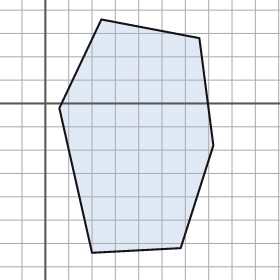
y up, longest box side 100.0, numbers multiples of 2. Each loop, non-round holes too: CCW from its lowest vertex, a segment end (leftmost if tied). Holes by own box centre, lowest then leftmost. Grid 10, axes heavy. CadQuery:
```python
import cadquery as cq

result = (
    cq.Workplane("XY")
    .moveTo(20.0, -64.0)
    .lineTo(58.0, -62.0)
    .lineTo(72.0, -18.0)
    .lineTo(66.0, 28.0)
    .lineTo(24.0, 36.0)
    .lineTo(6.0, -2.0)
    .close()
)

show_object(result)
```